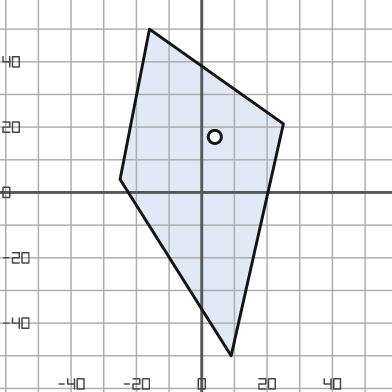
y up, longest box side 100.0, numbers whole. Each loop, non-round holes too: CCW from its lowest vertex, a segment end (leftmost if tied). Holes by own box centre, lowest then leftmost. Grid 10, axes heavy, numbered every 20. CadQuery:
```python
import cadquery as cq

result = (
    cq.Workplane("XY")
    .moveTo(9.0, -50.0)
    .lineTo(25.0, 21.0)
    .lineTo(-16.0, 50.0)
    .lineTo(-25.0, 4.0)
    .close()
    .moveTo(4.0, 17.0)
    .circle(2.0)
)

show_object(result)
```